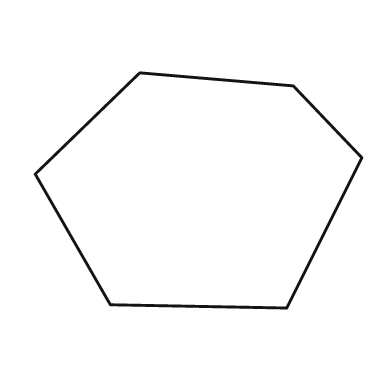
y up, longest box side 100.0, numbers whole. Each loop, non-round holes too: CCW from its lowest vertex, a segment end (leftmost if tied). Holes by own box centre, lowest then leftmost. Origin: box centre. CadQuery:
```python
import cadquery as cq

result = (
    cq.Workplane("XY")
    .moveTo(27.0, -36.0)
    .lineTo(50.0, 10.0)
    .lineTo(29.0, 32.0)
    .lineTo(-18.0, 36.0)
    .lineTo(-50.0, 5.0)
    .lineTo(-27.0, -35.0)
    .close()
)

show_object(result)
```